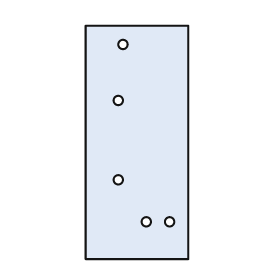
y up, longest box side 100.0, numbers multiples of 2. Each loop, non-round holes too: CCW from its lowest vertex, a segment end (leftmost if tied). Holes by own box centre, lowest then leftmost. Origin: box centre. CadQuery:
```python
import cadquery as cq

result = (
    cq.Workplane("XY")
    .moveTo(-22.0, -50.0)
    .lineTo(22.0, -50.0)
    .lineTo(22.0, 50.0)
    .lineTo(-22.0, 50.0)
    .close()
    .moveTo(4.0, -34.0)
    .circle(2.0)
    .moveTo(14.0, -34.0)
    .circle(2.0)
    .moveTo(-8.0, -16.0)
    .circle(2.0)
    .moveTo(-8.0, 18.0)
    .circle(2.0)
    .moveTo(-6.0, 42.0)
    .circle(2.0)
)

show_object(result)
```